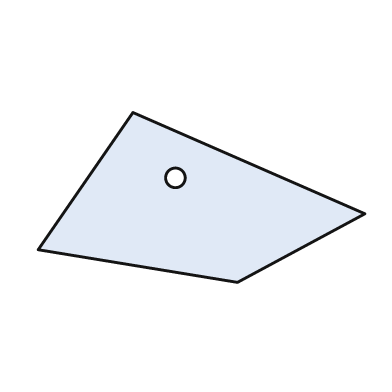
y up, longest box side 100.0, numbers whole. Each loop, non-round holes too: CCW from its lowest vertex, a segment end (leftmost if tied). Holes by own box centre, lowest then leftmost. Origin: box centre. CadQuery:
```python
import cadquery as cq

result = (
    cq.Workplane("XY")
    .moveTo(11.0, -26.0)
    .lineTo(50.0, -5.0)
    .lineTo(-21.0, 26.0)
    .lineTo(-50.0, -16.0)
    .close()
    .moveTo(-8.0, 6.0)
    .circle(3.0)
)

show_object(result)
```